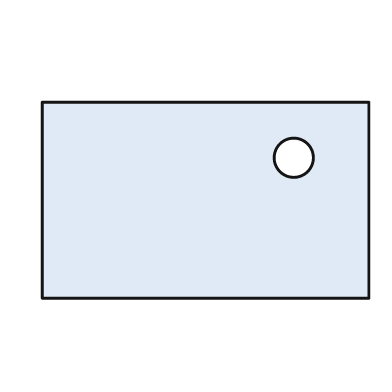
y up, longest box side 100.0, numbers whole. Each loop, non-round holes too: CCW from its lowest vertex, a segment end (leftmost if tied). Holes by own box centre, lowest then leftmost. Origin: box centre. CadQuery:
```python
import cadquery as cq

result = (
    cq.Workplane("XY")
    .moveTo(-50.0, -30.0)
    .lineTo(50.0, -30.0)
    .lineTo(50.0, 30.0)
    .lineTo(-50.0, 30.0)
    .close()
    .moveTo(27.0, 13.0)
    .circle(6.0)
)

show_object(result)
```